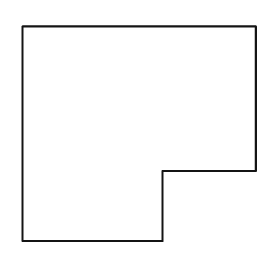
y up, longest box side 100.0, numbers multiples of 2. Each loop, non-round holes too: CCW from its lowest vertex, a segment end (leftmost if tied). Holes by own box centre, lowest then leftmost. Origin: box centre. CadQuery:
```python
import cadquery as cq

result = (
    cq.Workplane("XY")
    .moveTo(-50.0, -46.0)
    .lineTo(10.0, -46.0)
    .lineTo(10.0, -16.0)
    .lineTo(50.0, -16.0)
    .lineTo(50.0, 46.0)
    .lineTo(-50.0, 46.0)
    .close()
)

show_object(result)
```